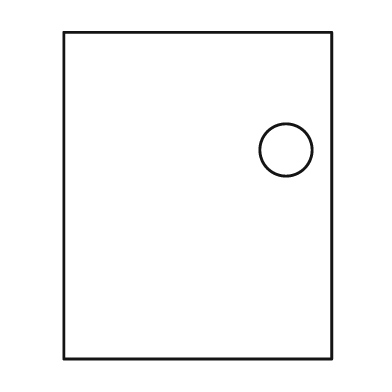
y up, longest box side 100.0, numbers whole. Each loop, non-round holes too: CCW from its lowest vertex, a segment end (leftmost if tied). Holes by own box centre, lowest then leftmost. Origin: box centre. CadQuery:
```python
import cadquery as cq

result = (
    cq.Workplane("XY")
    .moveTo(-41.0, -50.0)
    .lineTo(41.0, -50.0)
    .lineTo(41.0, 50.0)
    .lineTo(-41.0, 50.0)
    .close()
    .moveTo(27.0, 14.0)
    .circle(8.0)
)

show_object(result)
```